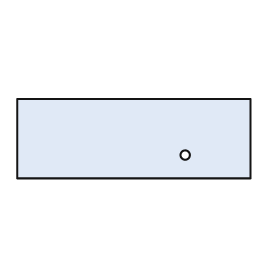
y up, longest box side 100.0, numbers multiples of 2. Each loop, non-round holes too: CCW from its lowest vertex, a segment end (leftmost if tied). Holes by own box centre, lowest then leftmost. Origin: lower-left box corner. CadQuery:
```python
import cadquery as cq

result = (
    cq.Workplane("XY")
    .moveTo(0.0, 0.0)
    .lineTo(100.0, 0.0)
    .lineTo(100.0, 34.0)
    .lineTo(0.0, 34.0)
    .close()
    .moveTo(72.0, 10.0)
    .circle(2.0)
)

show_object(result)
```